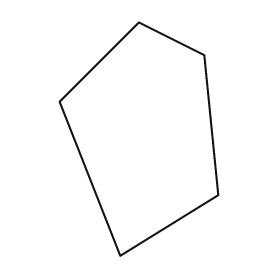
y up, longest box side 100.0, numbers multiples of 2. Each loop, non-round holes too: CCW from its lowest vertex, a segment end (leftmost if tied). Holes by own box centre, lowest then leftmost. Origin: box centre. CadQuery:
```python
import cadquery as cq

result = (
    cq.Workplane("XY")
    .moveTo(-8.0, -50.0)
    .lineTo(34.0, -24.0)
    .lineTo(28.0, 36.0)
    .lineTo(0.0, 50.0)
    .lineTo(-34.0, 16.0)
    .close()
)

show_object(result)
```